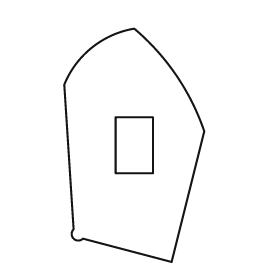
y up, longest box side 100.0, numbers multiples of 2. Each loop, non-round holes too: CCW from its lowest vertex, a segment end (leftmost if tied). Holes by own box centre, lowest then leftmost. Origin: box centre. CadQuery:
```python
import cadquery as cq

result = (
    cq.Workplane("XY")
    .moveTo(16.0, -50.0)
    .lineTo(30.0, 6.0)
    .threePointArc((18.0, 30.0), (0.0, 50.0))
    .threePointArc((-18.0, 42.0), (-30.0, 26.0))
    .lineTo(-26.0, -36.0)
    .threePointArc((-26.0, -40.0), (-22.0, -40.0))
    .close()
    .moveTo(-8.0, -12.0)
    .lineTo(8.0, -12.0)
    .lineTo(8.0, 12.0)
    .lineTo(-8.0, 12.0)
    .close()
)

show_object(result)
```